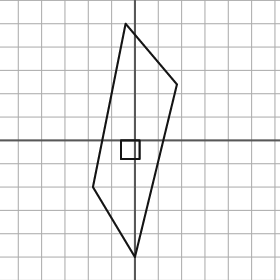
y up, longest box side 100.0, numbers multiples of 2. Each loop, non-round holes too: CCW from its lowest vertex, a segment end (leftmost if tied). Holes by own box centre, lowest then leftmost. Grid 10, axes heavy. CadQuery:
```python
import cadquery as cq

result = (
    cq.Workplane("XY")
    .moveTo(0.0, -50.0)
    .lineTo(18.0, 24.0)
    .lineTo(-4.0, 50.0)
    .lineTo(-18.0, -20.0)
    .close()
    .moveTo(-6.0, -8.0)
    .lineTo(2.0, -8.0)
    .lineTo(2.0, 0.0)
    .lineTo(-6.0, 0.0)
    .close()
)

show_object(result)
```